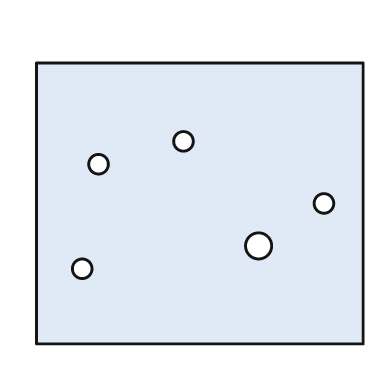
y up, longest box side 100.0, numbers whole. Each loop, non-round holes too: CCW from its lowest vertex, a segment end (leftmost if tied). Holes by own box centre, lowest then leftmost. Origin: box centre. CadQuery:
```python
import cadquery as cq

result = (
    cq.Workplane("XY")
    .moveTo(-50.0, -43.0)
    .lineTo(50.0, -43.0)
    .lineTo(50.0, 43.0)
    .lineTo(-50.0, 43.0)
    .close()
    .moveTo(-36.0, -20.0)
    .circle(3.0)
    .moveTo(18.0, -13.0)
    .circle(4.0)
    .moveTo(38.0, 0.0)
    .circle(3.0)
    .moveTo(-31.0, 12.0)
    .circle(3.0)
    .moveTo(-5.0, 19.0)
    .circle(3.0)
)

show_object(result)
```